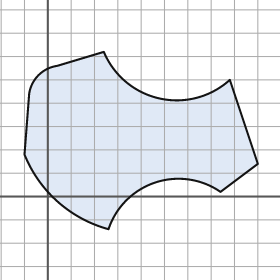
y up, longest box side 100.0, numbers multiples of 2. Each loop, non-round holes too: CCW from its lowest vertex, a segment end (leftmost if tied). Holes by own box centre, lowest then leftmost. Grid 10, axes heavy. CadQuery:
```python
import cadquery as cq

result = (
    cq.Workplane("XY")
    .moveTo(26.0, -14.0)
    .threePointArc((46.0, 6.0), (74.0, 2.0))
    .lineTo(90.0, 14.0)
    .lineTo(78.0, 50.0)
    .threePointArc((48.0, 42.0), (24.0, 62.0))
    .lineTo(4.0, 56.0)
    .threePointArc((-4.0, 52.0), (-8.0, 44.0))
    .lineTo(-10.0, 18.0)
    .threePointArc((4.0, -2.0), (26.0, -14.0))
    .close()
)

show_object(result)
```